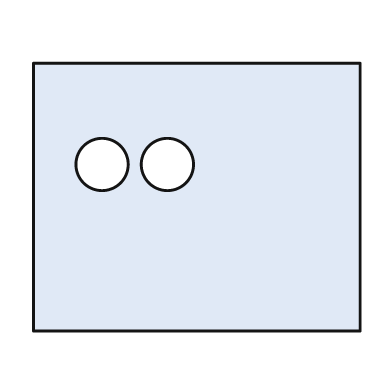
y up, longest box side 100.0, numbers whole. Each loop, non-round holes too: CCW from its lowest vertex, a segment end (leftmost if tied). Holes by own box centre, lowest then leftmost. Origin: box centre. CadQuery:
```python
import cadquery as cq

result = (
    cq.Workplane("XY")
    .moveTo(-50.0, -41.0)
    .lineTo(50.0, -41.0)
    .lineTo(50.0, 41.0)
    .lineTo(-50.0, 41.0)
    .close()
    .moveTo(-29.0, 10.0)
    .circle(8.0)
    .moveTo(-9.0, 10.0)
    .circle(8.0)
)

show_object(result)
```